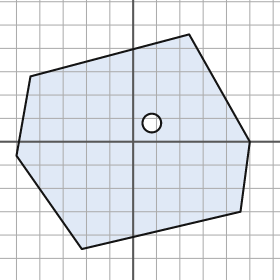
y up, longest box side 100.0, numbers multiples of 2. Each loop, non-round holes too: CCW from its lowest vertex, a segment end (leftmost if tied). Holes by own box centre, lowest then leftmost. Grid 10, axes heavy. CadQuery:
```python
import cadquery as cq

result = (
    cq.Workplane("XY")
    .moveTo(-22.0, -46.0)
    .lineTo(46.0, -30.0)
    .lineTo(50.0, 0.0)
    .lineTo(24.0, 46.0)
    .lineTo(-44.0, 28.0)
    .lineTo(-50.0, -6.0)
    .close()
    .moveTo(8.0, 8.0)
    .circle(4.0)
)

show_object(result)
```